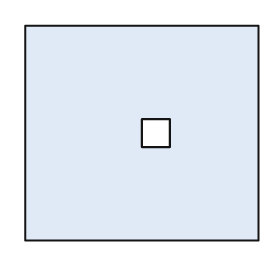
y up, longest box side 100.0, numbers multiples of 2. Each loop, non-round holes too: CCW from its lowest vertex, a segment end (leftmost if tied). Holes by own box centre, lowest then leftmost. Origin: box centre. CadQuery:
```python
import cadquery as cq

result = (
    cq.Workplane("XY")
    .moveTo(-50.0, -46.0)
    .lineTo(50.0, -46.0)
    .lineTo(50.0, 46.0)
    .lineTo(-50.0, 46.0)
    .close()
    .moveTo(0.0, -6.0)
    .lineTo(12.0, -6.0)
    .lineTo(12.0, 6.0)
    .lineTo(0.0, 6.0)
    .close()
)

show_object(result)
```